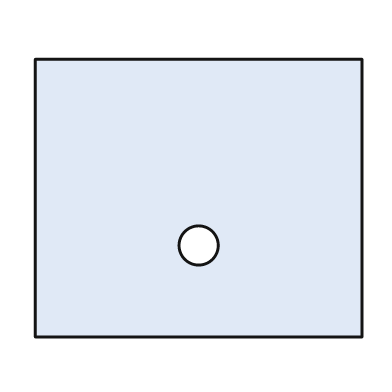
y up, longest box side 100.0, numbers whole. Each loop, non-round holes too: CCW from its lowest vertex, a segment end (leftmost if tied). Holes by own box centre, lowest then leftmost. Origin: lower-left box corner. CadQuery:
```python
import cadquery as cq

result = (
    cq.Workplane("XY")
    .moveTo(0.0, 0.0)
    .lineTo(100.0, 0.0)
    .lineTo(100.0, 85.0)
    .lineTo(0.0, 85.0)
    .close()
    .moveTo(50.0, 28.0)
    .circle(6.0)
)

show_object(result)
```